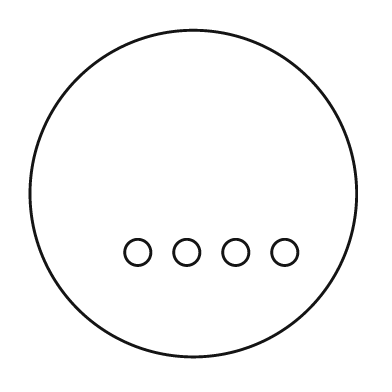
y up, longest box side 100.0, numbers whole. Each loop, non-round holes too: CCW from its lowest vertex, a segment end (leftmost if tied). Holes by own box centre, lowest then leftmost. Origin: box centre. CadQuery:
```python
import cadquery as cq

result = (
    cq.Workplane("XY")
    .moveTo(0.0, 0.0)
    .circle(50.0)
    .moveTo(-17.0, -18.0)
    .circle(4.0)
    .moveTo(-2.0, -18.0)
    .circle(4.0)
    .moveTo(13.0, -18.0)
    .circle(4.0)
    .moveTo(28.0, -18.0)
    .circle(4.0)
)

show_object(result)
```